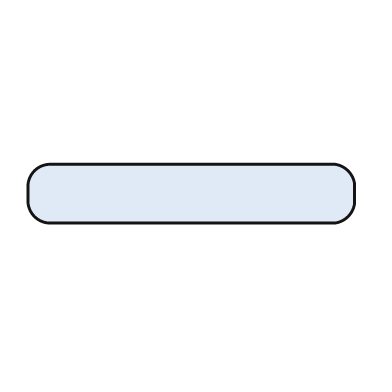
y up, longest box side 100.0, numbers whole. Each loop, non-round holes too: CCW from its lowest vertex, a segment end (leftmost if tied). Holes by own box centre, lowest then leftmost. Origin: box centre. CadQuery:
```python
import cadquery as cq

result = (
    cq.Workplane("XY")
    .moveTo(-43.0, -9.0)
    .lineTo(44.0, -9.0)
    .threePointArc((48.0, -7.0), (50.0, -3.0))
    .lineTo(50.0, 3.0)
    .threePointArc((48.0, 7.0), (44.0, 9.0))
    .lineTo(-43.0, 9.0)
    .threePointArc((-48.0, 7.0), (-50.0, 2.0))
    .lineTo(-50.0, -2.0)
    .threePointArc((-48.0, -7.0), (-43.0, -9.0))
    .close()
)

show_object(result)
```